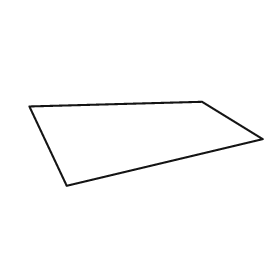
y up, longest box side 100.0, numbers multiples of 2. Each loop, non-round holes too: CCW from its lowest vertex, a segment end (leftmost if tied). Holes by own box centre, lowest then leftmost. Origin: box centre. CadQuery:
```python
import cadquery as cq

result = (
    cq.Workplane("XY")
    .moveTo(-34.0, -18.0)
    .lineTo(50.0, 2.0)
    .lineTo(24.0, 18.0)
    .lineTo(-50.0, 16.0)
    .close()
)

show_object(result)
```